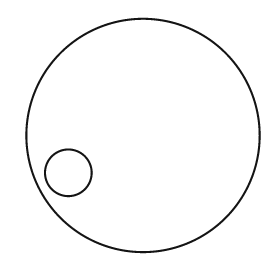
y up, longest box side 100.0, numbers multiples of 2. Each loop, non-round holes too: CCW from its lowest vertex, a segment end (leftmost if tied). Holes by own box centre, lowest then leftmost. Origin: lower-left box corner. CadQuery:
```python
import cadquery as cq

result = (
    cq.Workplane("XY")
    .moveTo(50.0, 50.0)
    .circle(50.0)
    .moveTo(18.0, 34.0)
    .circle(10.0)
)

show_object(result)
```